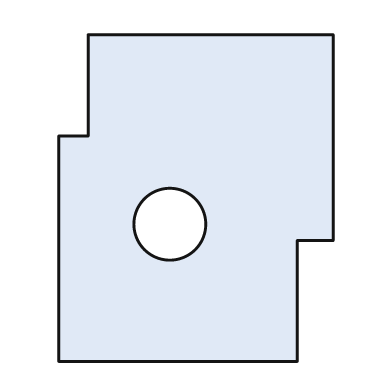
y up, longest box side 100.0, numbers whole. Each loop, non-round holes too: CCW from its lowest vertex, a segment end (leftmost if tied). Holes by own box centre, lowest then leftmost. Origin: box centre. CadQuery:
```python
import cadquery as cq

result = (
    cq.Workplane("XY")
    .moveTo(-42.0, -50.0)
    .lineTo(31.0, -50.0)
    .lineTo(31.0, -13.0)
    .lineTo(42.0, -13.0)
    .lineTo(42.0, 50.0)
    .lineTo(-33.0, 50.0)
    .lineTo(-33.0, 19.0)
    .lineTo(-42.0, 19.0)
    .close()
    .moveTo(-8.0, -8.0)
    .circle(11.0)
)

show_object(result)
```